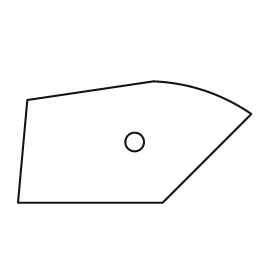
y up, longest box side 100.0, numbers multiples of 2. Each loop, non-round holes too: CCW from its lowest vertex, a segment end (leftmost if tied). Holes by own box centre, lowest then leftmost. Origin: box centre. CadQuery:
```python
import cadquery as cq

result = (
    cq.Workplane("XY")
    .moveTo(-50.0, -26.0)
    .lineTo(12.0, -26.0)
    .lineTo(50.0, 12.0)
    .threePointArc((30.0, 22.0), (8.0, 26.0))
    .lineTo(-46.0, 18.0)
    .close()
    .moveTo(0.0, 0.0)
    .circle(4.0)
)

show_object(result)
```